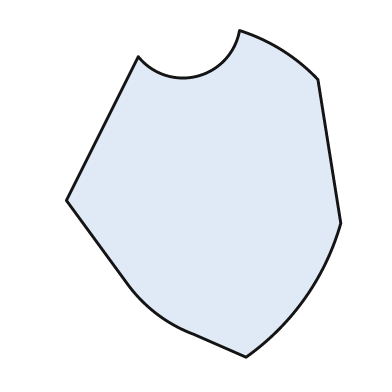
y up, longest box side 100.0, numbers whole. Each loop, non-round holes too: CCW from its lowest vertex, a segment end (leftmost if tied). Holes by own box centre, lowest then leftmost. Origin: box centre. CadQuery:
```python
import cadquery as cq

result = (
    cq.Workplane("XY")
    .moveTo(13.0, -50.0)
    .threePointArc((31.0, -32.0), (42.0, -9.0))
    .lineTo(35.0, 35.0)
    .threePointArc((24.0, 44.0), (11.0, 50.0))
    .threePointArc((-2.0, 36.0), (-20.0, 42.0))
    .lineTo(-42.0, -2.0)
    .lineTo(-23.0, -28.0)
    .threePointArc((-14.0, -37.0), (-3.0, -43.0))
    .close()
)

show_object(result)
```